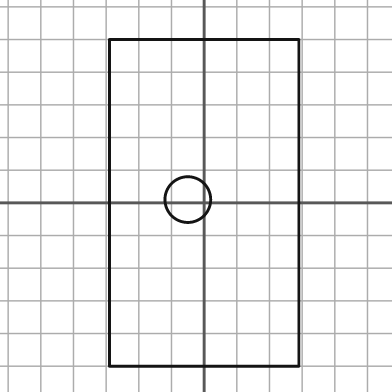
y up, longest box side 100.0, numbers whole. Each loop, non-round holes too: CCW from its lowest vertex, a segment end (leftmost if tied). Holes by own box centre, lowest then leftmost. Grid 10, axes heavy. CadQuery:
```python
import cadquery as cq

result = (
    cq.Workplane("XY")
    .moveTo(-29.0, -50.0)
    .lineTo(29.0, -50.0)
    .lineTo(29.0, 50.0)
    .lineTo(-29.0, 50.0)
    .close()
    .moveTo(-5.0, 1.0)
    .circle(7.0)
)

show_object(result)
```